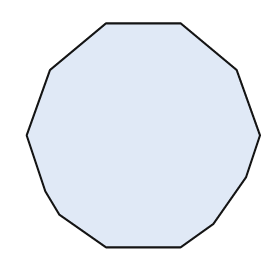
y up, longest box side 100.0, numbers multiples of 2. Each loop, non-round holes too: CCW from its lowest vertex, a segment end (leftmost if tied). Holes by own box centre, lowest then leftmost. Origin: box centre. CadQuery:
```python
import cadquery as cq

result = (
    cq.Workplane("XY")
    .moveTo(-16.0, -48.0)
    .lineTo(16.0, -48.0)
    .lineTo(30.0, -38.0)
    .lineTo(44.0, -18.0)
    .lineTo(50.0, 0.0)
    .lineTo(40.0, 28.0)
    .lineTo(16.0, 48.0)
    .lineTo(-16.0, 48.0)
    .lineTo(-40.0, 28.0)
    .lineTo(-50.0, 0.0)
    .lineTo(-42.0, -24.0)
    .lineTo(-36.0, -34.0)
    .close()
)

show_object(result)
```